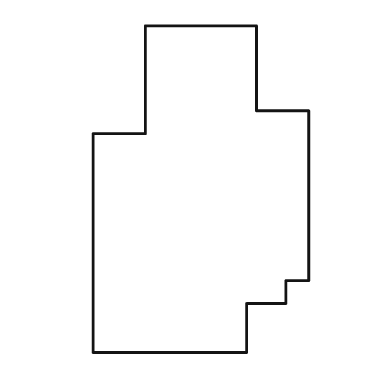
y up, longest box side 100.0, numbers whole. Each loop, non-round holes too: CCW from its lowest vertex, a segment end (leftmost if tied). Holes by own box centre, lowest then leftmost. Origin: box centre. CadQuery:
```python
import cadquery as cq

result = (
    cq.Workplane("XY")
    .moveTo(-33.0, -50.0)
    .lineTo(14.0, -50.0)
    .lineTo(14.0, -35.0)
    .lineTo(26.0, -35.0)
    .lineTo(26.0, -28.0)
    .lineTo(33.0, -28.0)
    .lineTo(33.0, 24.0)
    .lineTo(17.0, 24.0)
    .lineTo(17.0, 50.0)
    .lineTo(-17.0, 50.0)
    .lineTo(-17.0, 17.0)
    .lineTo(-33.0, 17.0)
    .close()
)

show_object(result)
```